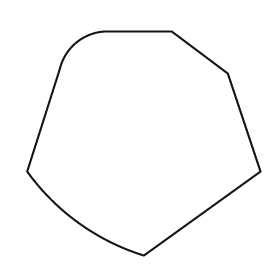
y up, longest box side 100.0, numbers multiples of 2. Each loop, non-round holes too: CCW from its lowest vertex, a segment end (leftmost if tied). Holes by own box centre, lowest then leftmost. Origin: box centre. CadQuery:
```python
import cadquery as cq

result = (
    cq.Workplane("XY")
    .moveTo(0.0, -48.0)
    .lineTo(50.0, -12.0)
    .lineTo(36.0, 30.0)
    .lineTo(12.0, 48.0)
    .lineTo(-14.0, 48.0)
    .threePointArc((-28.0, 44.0), (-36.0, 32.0))
    .lineTo(-50.0, -12.0)
    .threePointArc((-28.0, -34.0), (0.0, -48.0))
    .close()
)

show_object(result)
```